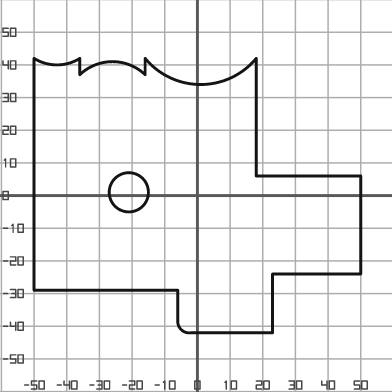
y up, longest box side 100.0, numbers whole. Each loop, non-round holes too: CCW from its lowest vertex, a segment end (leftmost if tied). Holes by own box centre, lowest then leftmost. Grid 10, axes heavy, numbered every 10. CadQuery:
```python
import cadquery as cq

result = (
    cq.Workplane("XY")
    .moveTo(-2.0, -42.0)
    .lineTo(23.0, -42.0)
    .lineTo(23.0, -24.0)
    .lineTo(50.0, -24.0)
    .lineTo(50.0, 6.0)
    .lineTo(18.0, 6.0)
    .lineTo(18.0, 42.0)
    .threePointArc((1.0, 34.0), (-16.0, 42.0))
    .lineTo(-16.0, 37.0)
    .threePointArc((-26.0, 41.0), (-36.0, 37.0))
    .lineTo(-36.0, 42.0)
    .threePointArc((-43.0, 40.0), (-50.0, 42.0))
    .lineTo(-50.0, -29.0)
    .lineTo(-6.0, -29.0)
    .lineTo(-6.0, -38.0)
    .threePointArc((-5.0, -41.0), (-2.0, -42.0))
    .close()
    .moveTo(-21.0, 1.0)
    .circle(6.0)
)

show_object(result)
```